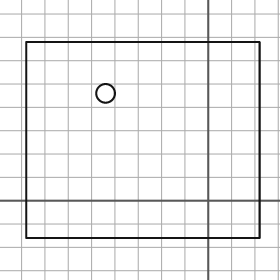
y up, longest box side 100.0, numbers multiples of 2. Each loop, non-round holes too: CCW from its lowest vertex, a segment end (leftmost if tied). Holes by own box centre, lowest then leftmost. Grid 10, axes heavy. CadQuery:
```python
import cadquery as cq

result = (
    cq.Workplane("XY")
    .moveTo(-78.0, -16.0)
    .lineTo(22.0, -16.0)
    .lineTo(22.0, 68.0)
    .lineTo(-78.0, 68.0)
    .close()
    .moveTo(-44.0, 46.0)
    .circle(4.0)
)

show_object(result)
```